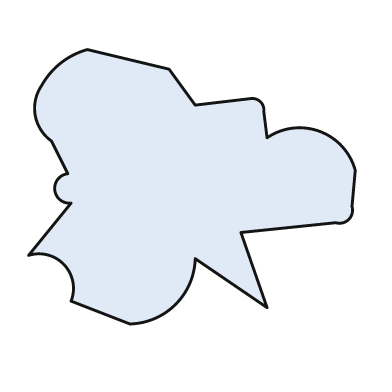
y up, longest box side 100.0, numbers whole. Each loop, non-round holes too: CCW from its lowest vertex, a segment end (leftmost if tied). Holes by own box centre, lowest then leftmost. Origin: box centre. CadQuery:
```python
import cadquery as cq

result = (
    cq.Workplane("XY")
    .moveTo(-19.0, -42.0)
    .threePointArc((-5.0, -36.0), (1.0, -22.0))
    .lineTo(23.0, -37.0)
    .lineTo(15.0, -14.0)
    .lineTo(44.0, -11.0)
    .threePointArc((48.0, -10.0), (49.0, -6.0))
    .lineTo(50.0, 5.0)
    .threePointArc((39.0, 17.0), (23.0, 15.0))
    .lineTo(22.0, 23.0)
    .threePointArc((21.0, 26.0), (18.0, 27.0))
    .lineTo(1.0, 25.0)
    .lineTo(-7.0, 36.0)
    .lineTo(-32.0, 42.0)
    .threePointArc((-40.0, 38.0), (-46.0, 31.0))
    .threePointArc((-48.0, 22.0), (-43.0, 14.0))
    .lineTo(-38.0, 4.0)
    .threePointArc((-42.0, -1.0), (-37.0, -5.0))
    .lineTo(-50.0, -21.0)
    .threePointArc((-39.0, -24.0), (-37.0, -35.0))
    .close()
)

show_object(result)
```